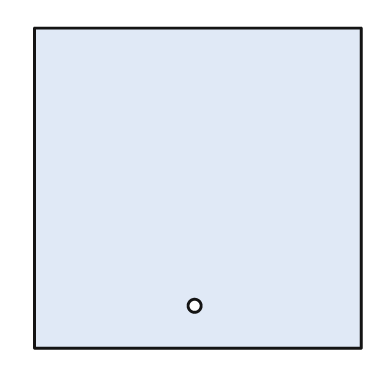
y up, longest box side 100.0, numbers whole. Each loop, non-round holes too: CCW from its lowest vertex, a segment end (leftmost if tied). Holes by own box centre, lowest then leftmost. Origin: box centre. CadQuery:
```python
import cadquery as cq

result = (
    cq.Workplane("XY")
    .moveTo(-50.0, -49.0)
    .lineTo(50.0, -49.0)
    .lineTo(50.0, 49.0)
    .lineTo(-50.0, 49.0)
    .close()
    .moveTo(-1.0, -36.0)
    .circle(2.0)
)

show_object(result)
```